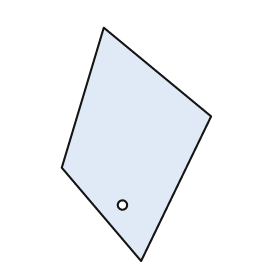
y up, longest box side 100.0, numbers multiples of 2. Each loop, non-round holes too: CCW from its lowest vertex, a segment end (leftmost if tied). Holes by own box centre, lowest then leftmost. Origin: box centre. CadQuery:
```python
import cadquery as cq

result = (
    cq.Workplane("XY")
    .moveTo(2.0, -50.0)
    .lineTo(32.0, 12.0)
    .lineTo(-14.0, 50.0)
    .lineTo(-32.0, -10.0)
    .close()
    .moveTo(-6.0, -26.0)
    .circle(2.0)
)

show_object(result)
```